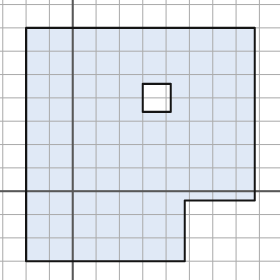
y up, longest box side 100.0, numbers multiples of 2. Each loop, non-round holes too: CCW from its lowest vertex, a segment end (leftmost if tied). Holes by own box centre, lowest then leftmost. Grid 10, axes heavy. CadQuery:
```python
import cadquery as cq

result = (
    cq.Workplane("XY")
    .moveTo(-20.0, -30.0)
    .lineTo(48.0, -30.0)
    .lineTo(48.0, -4.0)
    .lineTo(78.0, -4.0)
    .lineTo(78.0, 70.0)
    .lineTo(-20.0, 70.0)
    .close()
    .moveTo(30.0, 34.0)
    .lineTo(42.0, 34.0)
    .lineTo(42.0, 46.0)
    .lineTo(30.0, 46.0)
    .close()
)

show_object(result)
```